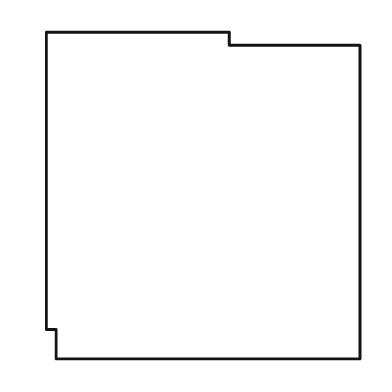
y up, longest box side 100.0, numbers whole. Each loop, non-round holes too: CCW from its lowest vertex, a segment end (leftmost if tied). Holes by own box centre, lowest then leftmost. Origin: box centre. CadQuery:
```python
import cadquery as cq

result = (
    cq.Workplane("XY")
    .moveTo(-45.0, -50.0)
    .lineTo(48.0, -50.0)
    .lineTo(48.0, 46.0)
    .lineTo(8.0, 46.0)
    .lineTo(8.0, 50.0)
    .lineTo(-48.0, 50.0)
    .lineTo(-48.0, -41.0)
    .lineTo(-45.0, -41.0)
    .close()
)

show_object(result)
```